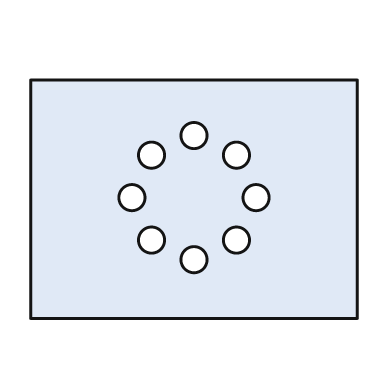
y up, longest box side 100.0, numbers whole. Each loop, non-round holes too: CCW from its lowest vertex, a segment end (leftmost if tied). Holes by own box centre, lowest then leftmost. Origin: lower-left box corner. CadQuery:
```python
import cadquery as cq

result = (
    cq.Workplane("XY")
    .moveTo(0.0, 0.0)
    .lineTo(100.0, 0.0)
    .lineTo(100.0, 73.0)
    .lineTo(0.0, 73.0)
    .close()
    .moveTo(50.0, 18.0)
    .circle(4.0)
    .moveTo(37.0, 24.0)
    .circle(4.0)
    .moveTo(63.0, 24.0)
    .circle(4.0)
    .moveTo(31.0, 37.0)
    .circle(4.0)
    .moveTo(69.0, 37.0)
    .circle(4.0)
    .moveTo(37.0, 50.0)
    .circle(4.0)
    .moveTo(63.0, 50.0)
    .circle(4.0)
    .moveTo(50.0, 56.0)
    .circle(4.0)
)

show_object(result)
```